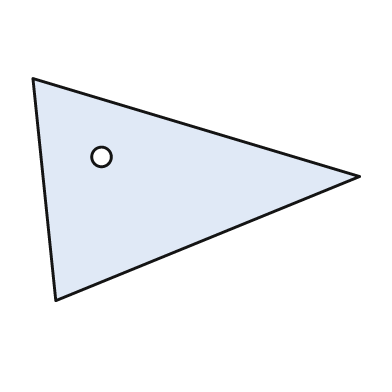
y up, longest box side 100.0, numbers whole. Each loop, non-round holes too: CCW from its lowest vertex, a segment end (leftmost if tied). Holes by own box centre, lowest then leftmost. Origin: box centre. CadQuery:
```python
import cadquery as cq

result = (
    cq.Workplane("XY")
    .moveTo(-43.0, -34.0)
    .lineTo(50.0, 4.0)
    .lineTo(-50.0, 34.0)
    .close()
    .moveTo(-29.0, 10.0)
    .circle(3.0)
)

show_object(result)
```